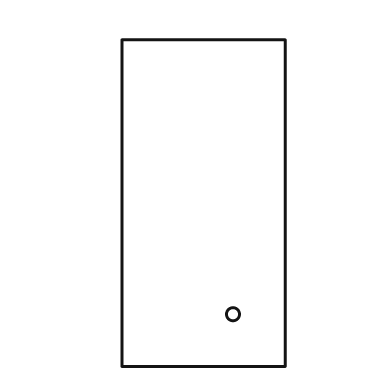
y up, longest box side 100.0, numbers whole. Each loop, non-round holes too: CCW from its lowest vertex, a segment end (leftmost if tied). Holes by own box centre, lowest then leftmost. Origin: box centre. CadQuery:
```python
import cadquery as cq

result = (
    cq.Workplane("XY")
    .moveTo(-25.0, -50.0)
    .lineTo(25.0, -50.0)
    .lineTo(25.0, 50.0)
    .lineTo(-25.0, 50.0)
    .close()
    .moveTo(9.0, -34.0)
    .circle(2.0)
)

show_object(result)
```